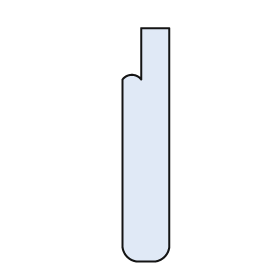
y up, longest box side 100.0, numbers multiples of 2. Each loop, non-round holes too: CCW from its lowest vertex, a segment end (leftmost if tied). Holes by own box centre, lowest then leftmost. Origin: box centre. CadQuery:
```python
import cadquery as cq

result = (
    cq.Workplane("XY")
    .moveTo(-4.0, -50.0)
    .lineTo(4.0, -50.0)
    .threePointArc((8.0, -48.0), (10.0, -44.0))
    .lineTo(10.0, 50.0)
    .lineTo(-2.0, 50.0)
    .lineTo(-2.0, 28.0)
    .threePointArc((-6.0, 30.0), (-10.0, 28.0))
    .lineTo(-10.0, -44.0)
    .threePointArc((-8.0, -48.0), (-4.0, -50.0))
    .close()
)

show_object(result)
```